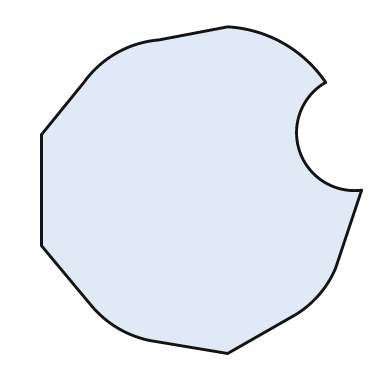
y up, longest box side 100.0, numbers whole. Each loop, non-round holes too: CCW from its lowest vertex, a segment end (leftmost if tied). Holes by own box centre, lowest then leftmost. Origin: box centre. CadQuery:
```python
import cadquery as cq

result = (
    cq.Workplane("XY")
    .moveTo(8.0, -50.0)
    .lineTo(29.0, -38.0)
    .threePointArc((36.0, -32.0), (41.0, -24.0))
    .lineTo(49.0, 0.0)
    .threePointArc((30.0, 12.0), (38.0, 33.0))
    .threePointArc((25.0, 45.0), (8.0, 50.0))
    .lineTo(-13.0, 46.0)
    .threePointArc((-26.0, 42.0), (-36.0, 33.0))
    .lineTo(-49.0, 17.0)
    .lineTo(-49.0, -17.0)
    .lineTo(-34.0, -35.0)
    .threePointArc((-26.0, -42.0), (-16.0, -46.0))
    .close()
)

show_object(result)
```